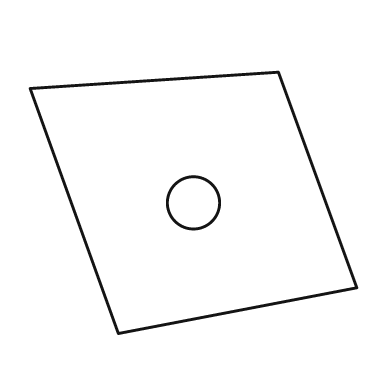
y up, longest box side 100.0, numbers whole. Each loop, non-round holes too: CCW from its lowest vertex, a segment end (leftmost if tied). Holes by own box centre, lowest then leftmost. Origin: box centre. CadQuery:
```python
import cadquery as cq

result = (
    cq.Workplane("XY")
    .moveTo(-23.0, -40.0)
    .lineTo(50.0, -26.0)
    .lineTo(26.0, 40.0)
    .lineTo(-50.0, 35.0)
    .close()
    .moveTo(0.0, 0.0)
    .circle(8.0)
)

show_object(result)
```